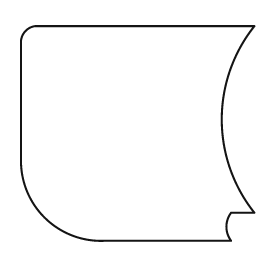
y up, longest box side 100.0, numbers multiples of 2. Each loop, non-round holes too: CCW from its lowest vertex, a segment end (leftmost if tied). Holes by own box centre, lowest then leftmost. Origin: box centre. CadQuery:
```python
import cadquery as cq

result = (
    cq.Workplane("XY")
    .moveTo(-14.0, -46.0)
    .lineTo(40.0, -46.0)
    .threePointArc((38.0, -40.0), (40.0, -34.0))
    .lineTo(50.0, -34.0)
    .threePointArc((36.0, 6.0), (50.0, 46.0))
    .lineTo(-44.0, 46.0)
    .threePointArc((-48.0, 44.0), (-50.0, 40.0))
    .lineTo(-50.0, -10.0)
    .threePointArc((-40.0, -36.0), (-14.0, -46.0))
    .close()
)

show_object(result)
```